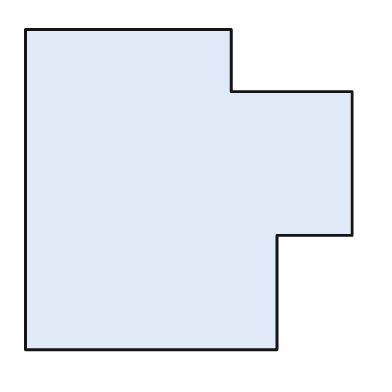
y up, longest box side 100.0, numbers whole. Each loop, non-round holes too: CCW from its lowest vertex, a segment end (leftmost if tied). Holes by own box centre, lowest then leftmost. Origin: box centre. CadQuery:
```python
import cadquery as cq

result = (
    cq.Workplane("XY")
    .moveTo(-50.0, -49.0)
    .lineTo(27.0, -49.0)
    .lineTo(27.0, -14.0)
    .lineTo(50.0, -14.0)
    .lineTo(50.0, 30.0)
    .lineTo(13.0, 30.0)
    .lineTo(13.0, 49.0)
    .lineTo(-50.0, 49.0)
    .close()
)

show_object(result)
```